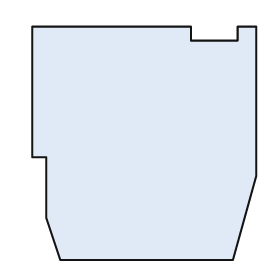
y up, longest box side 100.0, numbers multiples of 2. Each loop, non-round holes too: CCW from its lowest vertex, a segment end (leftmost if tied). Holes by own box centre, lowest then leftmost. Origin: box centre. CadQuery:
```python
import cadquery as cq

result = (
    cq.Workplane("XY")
    .moveTo(-36.0, -50.0)
    .lineTo(38.0, -50.0)
    .lineTo(48.0, -14.0)
    .lineTo(48.0, 50.0)
    .lineTo(40.0, 50.0)
    .lineTo(40.0, 44.0)
    .lineTo(20.0, 44.0)
    .lineTo(20.0, 50.0)
    .lineTo(-48.0, 50.0)
    .lineTo(-48.0, -6.0)
    .lineTo(-42.0, -6.0)
    .lineTo(-42.0, -32.0)
    .close()
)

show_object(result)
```